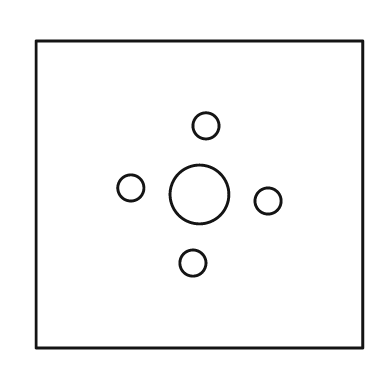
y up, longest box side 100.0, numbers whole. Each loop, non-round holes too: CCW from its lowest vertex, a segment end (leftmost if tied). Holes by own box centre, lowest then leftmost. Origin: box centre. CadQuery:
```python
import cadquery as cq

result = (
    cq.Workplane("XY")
    .moveTo(-50.0, -47.0)
    .lineTo(50.0, -47.0)
    .lineTo(50.0, 47.0)
    .lineTo(-50.0, 47.0)
    .close()
    .moveTo(-2.0, -21.0)
    .circle(4.0)
    .moveTo(21.0, -2.0)
    .circle(4.0)
    .moveTo(0.0, 0.0)
    .circle(9.0)
    .moveTo(-21.0, 2.0)
    .circle(4.0)
    .moveTo(2.0, 21.0)
    .circle(4.0)
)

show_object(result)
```